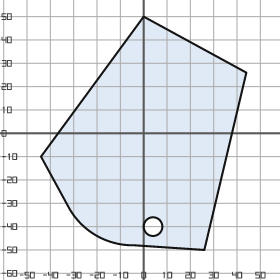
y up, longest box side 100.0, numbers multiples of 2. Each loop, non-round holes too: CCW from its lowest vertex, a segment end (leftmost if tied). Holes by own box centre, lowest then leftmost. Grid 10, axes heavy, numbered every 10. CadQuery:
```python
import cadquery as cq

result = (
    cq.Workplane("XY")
    .moveTo(26.0, -50.0)
    .lineTo(44.0, 26.0)
    .lineTo(0.0, 50.0)
    .lineTo(-44.0, -10.0)
    .lineTo(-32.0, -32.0)
    .threePointArc((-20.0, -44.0), (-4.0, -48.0))
    .close()
    .moveTo(4.0, -40.0)
    .circle(4.0)
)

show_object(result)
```